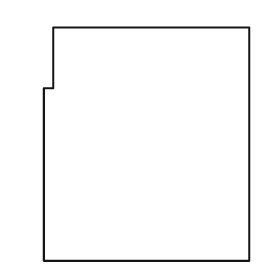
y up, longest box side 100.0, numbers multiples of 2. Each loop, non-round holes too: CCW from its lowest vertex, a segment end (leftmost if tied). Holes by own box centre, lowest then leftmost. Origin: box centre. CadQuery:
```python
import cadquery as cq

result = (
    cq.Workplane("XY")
    .moveTo(-44.0, -50.0)
    .lineTo(44.0, -50.0)
    .lineTo(44.0, 50.0)
    .lineTo(-40.0, 50.0)
    .lineTo(-40.0, 24.0)
    .lineTo(-44.0, 24.0)
    .close()
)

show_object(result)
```